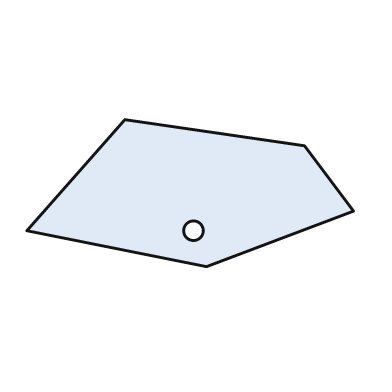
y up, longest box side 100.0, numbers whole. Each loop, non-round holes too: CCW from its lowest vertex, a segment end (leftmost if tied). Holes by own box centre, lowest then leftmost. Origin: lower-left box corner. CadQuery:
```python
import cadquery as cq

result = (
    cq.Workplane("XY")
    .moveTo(55.0, 0.0)
    .lineTo(100.0, 17.0)
    .lineTo(85.0, 37.0)
    .lineTo(30.0, 45.0)
    .lineTo(0.0, 11.0)
    .close()
    .moveTo(51.0, 11.0)
    .circle(3.0)
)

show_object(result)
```